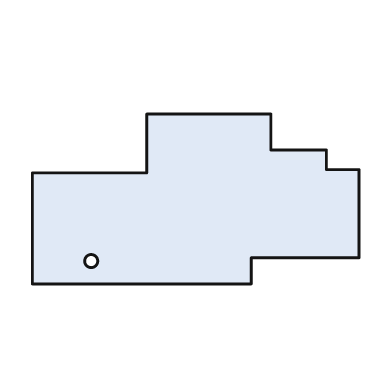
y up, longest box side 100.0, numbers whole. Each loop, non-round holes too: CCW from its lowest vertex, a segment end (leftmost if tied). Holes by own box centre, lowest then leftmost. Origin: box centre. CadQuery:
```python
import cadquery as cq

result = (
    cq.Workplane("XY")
    .moveTo(-50.0, -26.0)
    .lineTo(17.0, -26.0)
    .lineTo(17.0, -18.0)
    .lineTo(50.0, -18.0)
    .lineTo(50.0, 9.0)
    .lineTo(40.0, 9.0)
    .lineTo(40.0, 15.0)
    .lineTo(23.0, 15.0)
    .lineTo(23.0, 26.0)
    .lineTo(-15.0, 26.0)
    .lineTo(-15.0, 8.0)
    .lineTo(-50.0, 8.0)
    .close()
    .moveTo(-32.0, -19.0)
    .circle(2.0)
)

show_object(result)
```